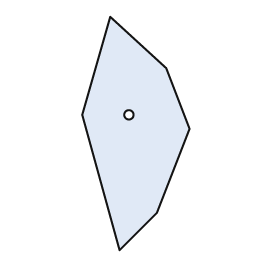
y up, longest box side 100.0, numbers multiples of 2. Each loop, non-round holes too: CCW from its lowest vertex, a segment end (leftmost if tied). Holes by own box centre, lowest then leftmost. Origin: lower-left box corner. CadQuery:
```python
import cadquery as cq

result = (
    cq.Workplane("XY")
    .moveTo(16.0, 0.0)
    .lineTo(32.0, 16.0)
    .lineTo(46.0, 52.0)
    .lineTo(36.0, 78.0)
    .lineTo(12.0, 100.0)
    .lineTo(0.0, 58.0)
    .close()
    .moveTo(20.0, 58.0)
    .circle(2.0)
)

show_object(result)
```